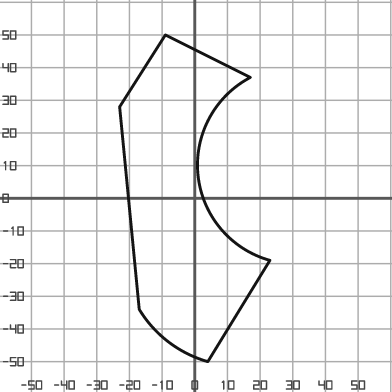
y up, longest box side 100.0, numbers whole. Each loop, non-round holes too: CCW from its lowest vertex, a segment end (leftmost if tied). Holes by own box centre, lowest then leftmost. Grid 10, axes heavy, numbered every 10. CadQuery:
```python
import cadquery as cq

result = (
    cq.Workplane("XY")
    .moveTo(4.0, -50.0)
    .lineTo(23.0, -19.0)
    .threePointArc((1.0, 7.0), (17.0, 37.0))
    .lineTo(-9.0, 50.0)
    .lineTo(-23.0, 28.0)
    .lineTo(-17.0, -34.0)
    .threePointArc((-8.0, -44.0), (4.0, -50.0))
    .close()
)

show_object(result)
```